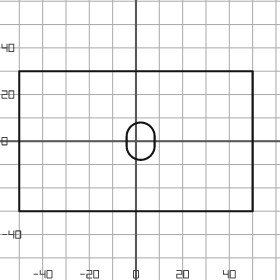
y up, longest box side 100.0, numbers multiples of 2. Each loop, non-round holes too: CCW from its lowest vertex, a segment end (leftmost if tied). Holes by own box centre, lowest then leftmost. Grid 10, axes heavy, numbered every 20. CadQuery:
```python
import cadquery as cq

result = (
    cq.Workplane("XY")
    .moveTo(-50.0, -30.0)
    .lineTo(50.0, -30.0)
    .lineTo(50.0, 30.0)
    .lineTo(-50.0, 30.0)
    .close()
    .moveTo(-4.0, -2.0)
    .threePointArc((2.0, -8.0), (8.0, -2.0))
    .lineTo(8.0, 2.0)
    .threePointArc((2.0, 8.0), (-4.0, 2.0))
    .close()
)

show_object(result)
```